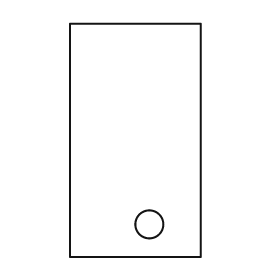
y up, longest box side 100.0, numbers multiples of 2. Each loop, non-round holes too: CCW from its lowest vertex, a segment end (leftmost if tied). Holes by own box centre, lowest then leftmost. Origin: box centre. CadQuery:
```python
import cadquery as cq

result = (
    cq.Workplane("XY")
    .moveTo(-28.0, -50.0)
    .lineTo(28.0, -50.0)
    .lineTo(28.0, 50.0)
    .lineTo(-28.0, 50.0)
    .close()
    .moveTo(6.0, -36.0)
    .circle(6.0)
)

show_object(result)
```